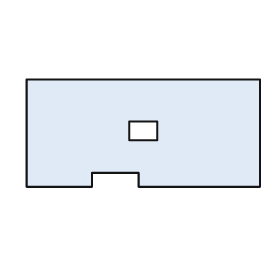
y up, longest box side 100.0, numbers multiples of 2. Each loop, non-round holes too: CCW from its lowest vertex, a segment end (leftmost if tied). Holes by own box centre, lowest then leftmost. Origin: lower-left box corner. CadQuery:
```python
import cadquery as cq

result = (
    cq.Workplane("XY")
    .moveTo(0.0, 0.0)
    .lineTo(28.0, 0.0)
    .lineTo(28.0, 6.0)
    .lineTo(48.0, 6.0)
    .lineTo(48.0, 0.0)
    .lineTo(100.0, 0.0)
    .lineTo(100.0, 46.0)
    .lineTo(0.0, 46.0)
    .close()
    .moveTo(44.0, 20.0)
    .lineTo(56.0, 20.0)
    .lineTo(56.0, 28.0)
    .lineTo(44.0, 28.0)
    .close()
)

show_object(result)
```